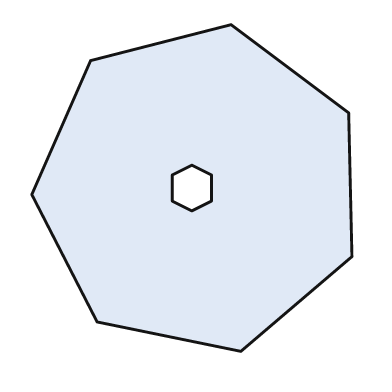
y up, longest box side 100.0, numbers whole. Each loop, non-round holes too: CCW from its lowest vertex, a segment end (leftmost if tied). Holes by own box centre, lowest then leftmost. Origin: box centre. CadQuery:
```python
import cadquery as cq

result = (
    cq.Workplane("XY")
    .moveTo(15.0, -50.0)
    .lineTo(49.0, -21.0)
    .lineTo(48.0, 23.0)
    .lineTo(12.0, 50.0)
    .lineTo(-31.0, 39.0)
    .lineTo(-49.0, -2.0)
    .lineTo(-29.0, -41.0)
    .close()
    .moveTo(0.0, -7.0)
    .lineTo(6.0, -4.0)
    .lineTo(6.0, 4.0)
    .lineTo(0.0, 7.0)
    .lineTo(-6.0, 4.0)
    .lineTo(-6.0, -4.0)
    .close()
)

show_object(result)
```